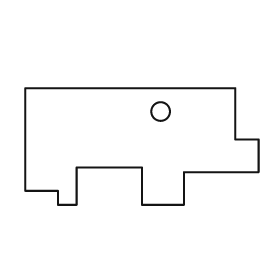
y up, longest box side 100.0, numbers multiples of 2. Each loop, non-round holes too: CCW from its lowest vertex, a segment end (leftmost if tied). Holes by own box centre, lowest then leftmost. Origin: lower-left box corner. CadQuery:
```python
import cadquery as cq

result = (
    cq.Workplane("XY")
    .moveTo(14.0, 0.0)
    .lineTo(22.0, 0.0)
    .lineTo(22.0, 16.0)
    .lineTo(50.0, 16.0)
    .lineTo(50.0, 0.0)
    .lineTo(68.0, 0.0)
    .lineTo(68.0, 14.0)
    .lineTo(100.0, 14.0)
    .lineTo(100.0, 28.0)
    .lineTo(90.0, 28.0)
    .lineTo(90.0, 50.0)
    .lineTo(0.0, 50.0)
    .lineTo(0.0, 6.0)
    .lineTo(14.0, 6.0)
    .close()
    .moveTo(58.0, 40.0)
    .circle(4.0)
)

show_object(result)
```